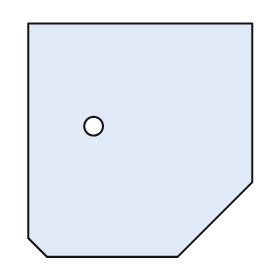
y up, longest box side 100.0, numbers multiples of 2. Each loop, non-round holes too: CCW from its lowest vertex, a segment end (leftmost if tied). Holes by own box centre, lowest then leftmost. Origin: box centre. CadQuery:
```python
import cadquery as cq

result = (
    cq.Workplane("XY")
    .moveTo(-40.0, -50.0)
    .lineTo(16.0, -50.0)
    .lineTo(48.0, -18.0)
    .lineTo(48.0, 50.0)
    .lineTo(-48.0, 50.0)
    .lineTo(-48.0, -42.0)
    .close()
    .moveTo(-20.0, 6.0)
    .circle(4.0)
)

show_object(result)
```